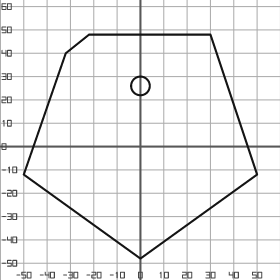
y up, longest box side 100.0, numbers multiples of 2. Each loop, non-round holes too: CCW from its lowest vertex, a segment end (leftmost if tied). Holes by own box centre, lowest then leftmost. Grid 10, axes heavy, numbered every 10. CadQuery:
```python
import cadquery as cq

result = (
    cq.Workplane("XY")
    .moveTo(0.0, -48.0)
    .lineTo(50.0, -12.0)
    .lineTo(30.0, 48.0)
    .lineTo(-22.0, 48.0)
    .lineTo(-32.0, 40.0)
    .lineTo(-50.0, -12.0)
    .close()
    .moveTo(0.0, 26.0)
    .circle(4.0)
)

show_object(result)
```